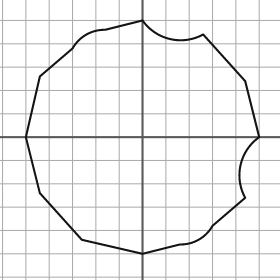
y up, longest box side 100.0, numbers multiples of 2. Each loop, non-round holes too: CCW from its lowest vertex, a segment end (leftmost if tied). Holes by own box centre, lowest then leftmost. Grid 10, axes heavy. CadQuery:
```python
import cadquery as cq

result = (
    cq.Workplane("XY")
    .moveTo(0.0, -50.0)
    .lineTo(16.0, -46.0)
    .threePointArc((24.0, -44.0), (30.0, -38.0))
    .lineTo(44.0, -26.0)
    .threePointArc((42.0, -12.0), (50.0, 0.0))
    .lineTo(44.0, 24.0)
    .lineTo(26.0, 44.0)
    .threePointArc((12.0, 42.0), (0.0, 50.0))
    .lineTo(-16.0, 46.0)
    .threePointArc((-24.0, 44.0), (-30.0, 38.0))
    .lineTo(-44.0, 26.0)
    .lineTo(-50.0, 0.0)
    .lineTo(-44.0, -24.0)
    .lineTo(-26.0, -44.0)
    .close()
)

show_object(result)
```